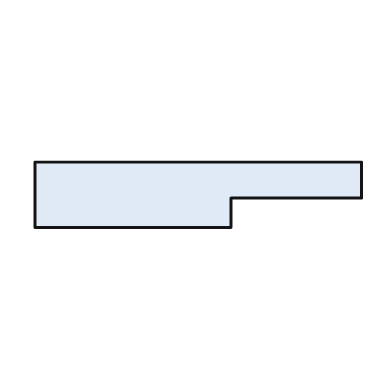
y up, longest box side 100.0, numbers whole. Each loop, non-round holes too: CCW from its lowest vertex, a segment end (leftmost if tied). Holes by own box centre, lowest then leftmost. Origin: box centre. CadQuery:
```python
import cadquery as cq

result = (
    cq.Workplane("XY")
    .moveTo(-50.0, -10.0)
    .lineTo(10.0, -10.0)
    .lineTo(10.0, -1.0)
    .lineTo(50.0, -1.0)
    .lineTo(50.0, 10.0)
    .lineTo(-50.0, 10.0)
    .close()
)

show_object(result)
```